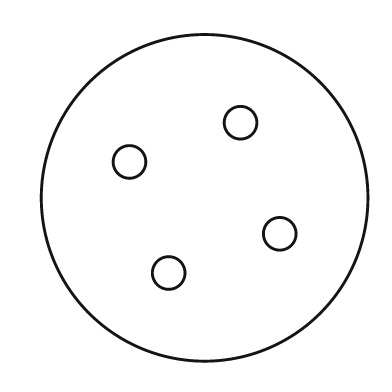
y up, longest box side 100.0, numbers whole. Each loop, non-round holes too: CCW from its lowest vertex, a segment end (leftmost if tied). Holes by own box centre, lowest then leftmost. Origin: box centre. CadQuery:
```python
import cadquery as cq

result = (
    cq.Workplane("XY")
    .moveTo(0.0, 0.0)
    .circle(50.0)
    .moveTo(-11.0, -23.0)
    .circle(5.0)
    .moveTo(23.0, -11.0)
    .circle(5.0)
    .moveTo(-23.0, 11.0)
    .circle(5.0)
    .moveTo(11.0, 23.0)
    .circle(5.0)
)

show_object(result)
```